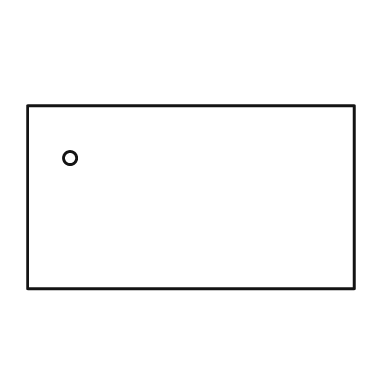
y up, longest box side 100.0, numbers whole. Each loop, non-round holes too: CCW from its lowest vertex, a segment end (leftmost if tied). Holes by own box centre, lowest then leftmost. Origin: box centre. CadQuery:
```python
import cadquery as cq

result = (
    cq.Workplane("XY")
    .moveTo(-50.0, -28.0)
    .lineTo(50.0, -28.0)
    .lineTo(50.0, 28.0)
    .lineTo(-50.0, 28.0)
    .close()
    .moveTo(-37.0, 12.0)
    .circle(2.0)
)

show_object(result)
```